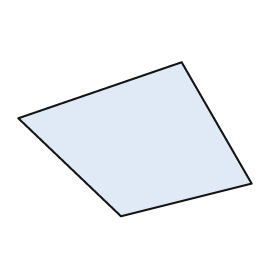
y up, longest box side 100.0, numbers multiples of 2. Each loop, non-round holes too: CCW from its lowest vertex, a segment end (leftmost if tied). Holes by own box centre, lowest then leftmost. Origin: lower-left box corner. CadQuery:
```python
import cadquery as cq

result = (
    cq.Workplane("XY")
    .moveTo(44.0, 0.0)
    .lineTo(100.0, 14.0)
    .lineTo(70.0, 66.0)
    .lineTo(0.0, 42.0)
    .close()
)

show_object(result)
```